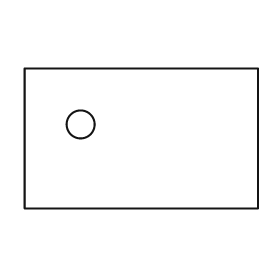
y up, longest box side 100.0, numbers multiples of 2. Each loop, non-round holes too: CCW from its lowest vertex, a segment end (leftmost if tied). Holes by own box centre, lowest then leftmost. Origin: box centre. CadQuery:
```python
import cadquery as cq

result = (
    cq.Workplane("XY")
    .moveTo(-50.0, -30.0)
    .lineTo(50.0, -30.0)
    .lineTo(50.0, 30.0)
    .lineTo(-50.0, 30.0)
    .close()
    .moveTo(-26.0, 6.0)
    .circle(6.0)
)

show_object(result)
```